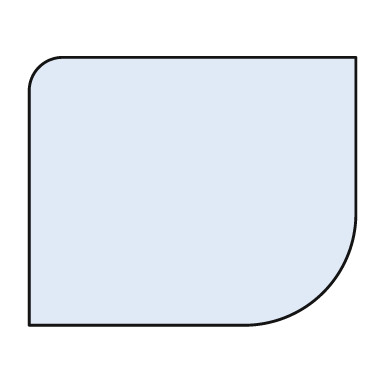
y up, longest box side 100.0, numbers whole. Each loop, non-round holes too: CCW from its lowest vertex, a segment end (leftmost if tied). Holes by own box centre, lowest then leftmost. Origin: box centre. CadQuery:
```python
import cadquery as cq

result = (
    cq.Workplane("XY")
    .moveTo(-50.0, -41.0)
    .lineTo(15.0, -41.0)
    .threePointArc((40.0, -31.0), (50.0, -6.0))
    .lineTo(50.0, 41.0)
    .lineTo(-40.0, 41.0)
    .threePointArc((-47.0, 38.0), (-50.0, 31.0))
    .close()
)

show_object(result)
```